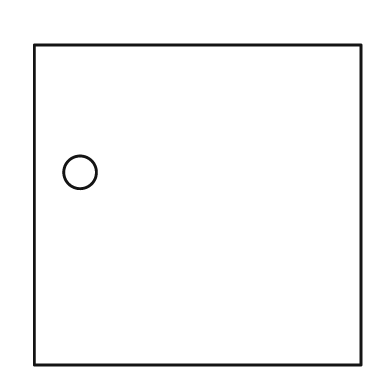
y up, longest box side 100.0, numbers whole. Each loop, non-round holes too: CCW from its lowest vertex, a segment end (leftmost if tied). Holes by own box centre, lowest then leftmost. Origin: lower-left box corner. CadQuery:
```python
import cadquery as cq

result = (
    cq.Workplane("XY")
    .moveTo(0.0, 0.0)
    .lineTo(100.0, 0.0)
    .lineTo(100.0, 98.0)
    .lineTo(0.0, 98.0)
    .close()
    .moveTo(14.0, 59.0)
    .circle(5.0)
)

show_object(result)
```